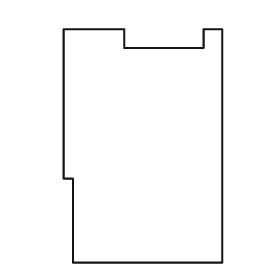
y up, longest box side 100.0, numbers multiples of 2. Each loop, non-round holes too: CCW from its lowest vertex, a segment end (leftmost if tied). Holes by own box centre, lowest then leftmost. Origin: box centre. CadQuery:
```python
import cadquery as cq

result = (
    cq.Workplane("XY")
    .moveTo(-30.0, -50.0)
    .lineTo(34.0, -50.0)
    .lineTo(34.0, 50.0)
    .lineTo(26.0, 50.0)
    .lineTo(26.0, 42.0)
    .lineTo(-8.0, 42.0)
    .lineTo(-8.0, 50.0)
    .lineTo(-34.0, 50.0)
    .lineTo(-34.0, -14.0)
    .lineTo(-30.0, -14.0)
    .close()
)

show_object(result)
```